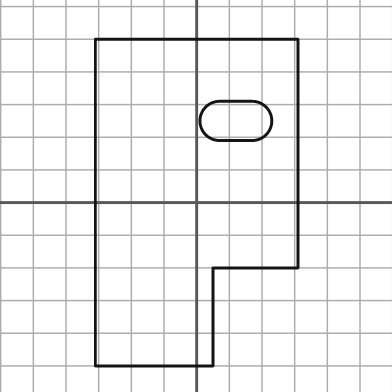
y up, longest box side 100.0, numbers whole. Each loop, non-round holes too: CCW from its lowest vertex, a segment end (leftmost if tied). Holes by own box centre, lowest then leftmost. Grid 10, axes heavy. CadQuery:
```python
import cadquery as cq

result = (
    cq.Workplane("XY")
    .moveTo(-31.0, -50.0)
    .lineTo(5.0, -50.0)
    .lineTo(5.0, -20.0)
    .lineTo(31.0, -20.0)
    .lineTo(31.0, 50.0)
    .lineTo(-31.0, 50.0)
    .close()
    .moveTo(7.0, 19.0)
    .lineTo(17.0, 19.0)
    .threePointArc((23.0, 25.0), (17.0, 31.0))
    .lineTo(7.0, 31.0)
    .threePointArc((1.0, 25.0), (7.0, 19.0))
    .close()
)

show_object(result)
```